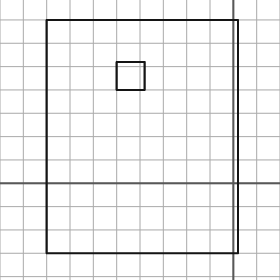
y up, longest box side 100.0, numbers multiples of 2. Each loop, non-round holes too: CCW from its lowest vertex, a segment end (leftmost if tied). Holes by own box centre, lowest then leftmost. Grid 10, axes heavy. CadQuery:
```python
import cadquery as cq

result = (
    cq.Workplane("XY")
    .moveTo(-80.0, -30.0)
    .lineTo(2.0, -30.0)
    .lineTo(2.0, 70.0)
    .lineTo(-80.0, 70.0)
    .close()
    .moveTo(-50.0, 40.0)
    .lineTo(-38.0, 40.0)
    .lineTo(-38.0, 52.0)
    .lineTo(-50.0, 52.0)
    .close()
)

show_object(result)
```